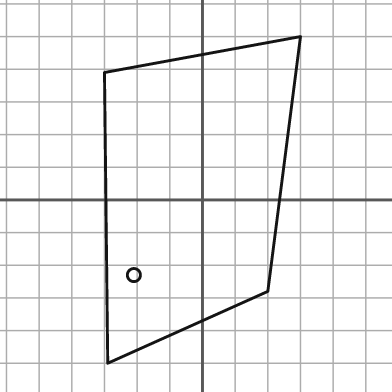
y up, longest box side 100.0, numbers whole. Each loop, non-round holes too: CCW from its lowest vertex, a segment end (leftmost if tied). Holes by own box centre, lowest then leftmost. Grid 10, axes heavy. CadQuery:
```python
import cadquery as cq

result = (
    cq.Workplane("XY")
    .moveTo(-29.0, -50.0)
    .lineTo(20.0, -28.0)
    .lineTo(30.0, 50.0)
    .lineTo(-30.0, 39.0)
    .close()
    .moveTo(-21.0, -23.0)
    .circle(2.0)
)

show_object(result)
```